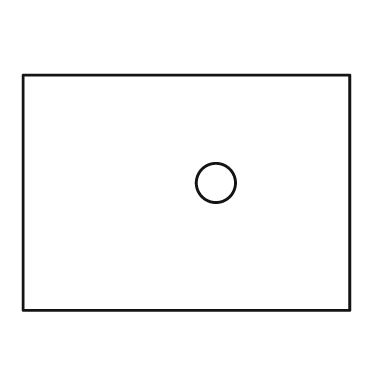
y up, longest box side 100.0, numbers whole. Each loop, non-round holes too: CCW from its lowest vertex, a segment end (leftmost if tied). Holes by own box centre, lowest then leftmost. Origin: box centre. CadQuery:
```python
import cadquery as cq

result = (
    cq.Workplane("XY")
    .moveTo(-50.0, -36.0)
    .lineTo(50.0, -36.0)
    .lineTo(50.0, 36.0)
    .lineTo(-50.0, 36.0)
    .close()
    .moveTo(9.0, 3.0)
    .circle(6.0)
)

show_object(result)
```